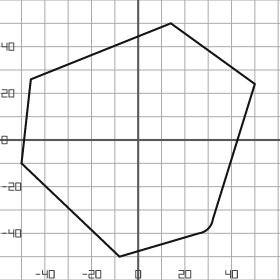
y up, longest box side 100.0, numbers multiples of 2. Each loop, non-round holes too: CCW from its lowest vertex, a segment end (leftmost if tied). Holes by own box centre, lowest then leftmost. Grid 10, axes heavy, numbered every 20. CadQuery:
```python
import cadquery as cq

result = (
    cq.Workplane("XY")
    .moveTo(-8.0, -50.0)
    .lineTo(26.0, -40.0)
    .threePointArc((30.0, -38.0), (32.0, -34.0))
    .lineTo(50.0, 24.0)
    .lineTo(14.0, 50.0)
    .lineTo(-46.0, 26.0)
    .lineTo(-50.0, -10.0)
    .close()
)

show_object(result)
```